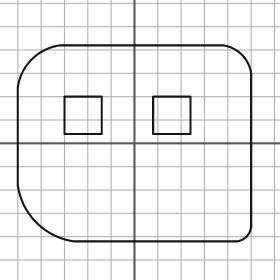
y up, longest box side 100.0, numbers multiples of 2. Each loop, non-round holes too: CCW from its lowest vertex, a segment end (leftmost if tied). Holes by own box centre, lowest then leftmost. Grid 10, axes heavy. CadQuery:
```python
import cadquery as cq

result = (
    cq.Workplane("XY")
    .moveTo(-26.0, -42.0)
    .lineTo(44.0, -42.0)
    .threePointArc((48.0, -40.0), (50.0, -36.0))
    .lineTo(50.0, 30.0)
    .threePointArc((46.0, 38.0), (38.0, 42.0))
    .lineTo(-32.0, 42.0)
    .threePointArc((-44.0, 36.0), (-50.0, 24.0))
    .lineTo(-50.0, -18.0)
    .threePointArc((-42.0, -34.0), (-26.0, -42.0))
    .close()
    .moveTo(-30.0, 4.0)
    .lineTo(-14.0, 4.0)
    .lineTo(-14.0, 20.0)
    .lineTo(-30.0, 20.0)
    .close()
    .moveTo(8.0, 4.0)
    .lineTo(24.0, 4.0)
    .lineTo(24.0, 20.0)
    .lineTo(8.0, 20.0)
    .close()
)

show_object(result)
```